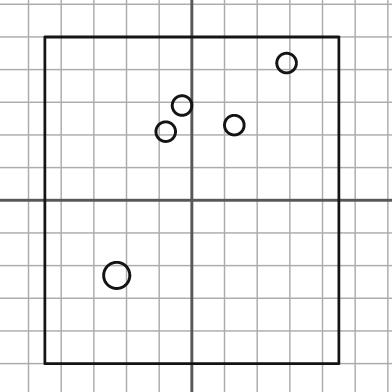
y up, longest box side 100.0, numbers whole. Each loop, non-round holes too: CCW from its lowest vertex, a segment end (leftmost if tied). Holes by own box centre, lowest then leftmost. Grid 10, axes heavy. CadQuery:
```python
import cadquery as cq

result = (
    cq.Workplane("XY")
    .moveTo(-45.0, -50.0)
    .lineTo(45.0, -50.0)
    .lineTo(45.0, 50.0)
    .lineTo(-45.0, 50.0)
    .close()
    .moveTo(-23.0, -23.0)
    .circle(4.0)
    .moveTo(-8.0, 21.0)
    .circle(3.0)
    .moveTo(13.0, 23.0)
    .circle(3.0)
    .moveTo(-3.0, 29.0)
    .circle(3.0)
    .moveTo(29.0, 42.0)
    .circle(3.0)
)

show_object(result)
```